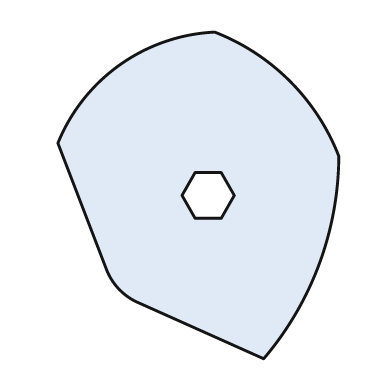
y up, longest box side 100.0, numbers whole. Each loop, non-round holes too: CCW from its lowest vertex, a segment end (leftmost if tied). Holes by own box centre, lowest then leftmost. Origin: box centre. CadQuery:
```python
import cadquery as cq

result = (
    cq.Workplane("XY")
    .moveTo(20.0, -50.0)
    .threePointArc((37.0, -21.0), (43.0, 12.0))
    .threePointArc((28.0, 35.0), (5.0, 50.0))
    .threePointArc((-24.0, 40.0), (-43.0, 16.0))
    .lineTo(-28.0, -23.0)
    .threePointArc((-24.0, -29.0), (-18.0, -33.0))
    .close()
    .moveTo(-1.0, -7.0)
    .lineTo(7.0, -7.0)
    .lineTo(11.0, 0.0)
    .lineTo(7.0, 7.0)
    .lineTo(-1.0, 7.0)
    .lineTo(-5.0, 0.0)
    .close()
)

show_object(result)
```